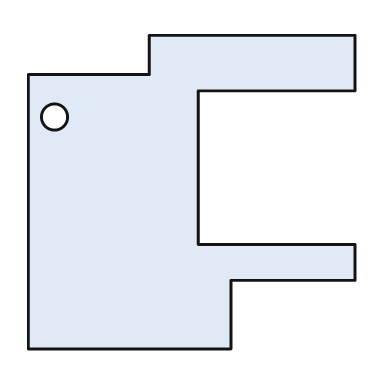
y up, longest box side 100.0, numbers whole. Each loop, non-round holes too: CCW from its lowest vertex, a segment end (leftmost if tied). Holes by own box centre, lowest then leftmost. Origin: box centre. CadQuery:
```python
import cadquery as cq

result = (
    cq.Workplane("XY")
    .moveTo(-50.0, -48.0)
    .lineTo(12.0, -48.0)
    .lineTo(12.0, -27.0)
    .lineTo(50.0, -27.0)
    .lineTo(50.0, -16.0)
    .lineTo(2.0, -16.0)
    .lineTo(2.0, 31.0)
    .lineTo(50.0, 31.0)
    .lineTo(50.0, 48.0)
    .lineTo(-13.0, 48.0)
    .lineTo(-13.0, 36.0)
    .lineTo(-50.0, 36.0)
    .close()
    .moveTo(-42.0, 23.0)
    .circle(4.0)
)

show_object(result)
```